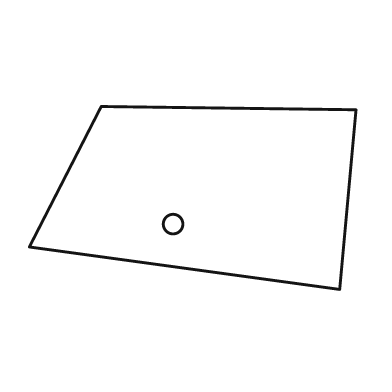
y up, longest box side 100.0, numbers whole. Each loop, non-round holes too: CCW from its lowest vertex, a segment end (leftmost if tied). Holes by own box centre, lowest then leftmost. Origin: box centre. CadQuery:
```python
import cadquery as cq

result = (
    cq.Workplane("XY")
    .moveTo(45.0, -28.0)
    .lineTo(50.0, 27.0)
    .lineTo(-28.0, 28.0)
    .lineTo(-50.0, -15.0)
    .close()
    .moveTo(-6.0, -8.0)
    .circle(3.0)
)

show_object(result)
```